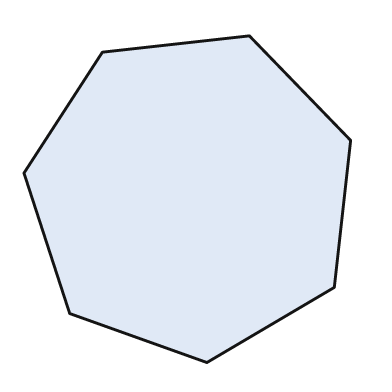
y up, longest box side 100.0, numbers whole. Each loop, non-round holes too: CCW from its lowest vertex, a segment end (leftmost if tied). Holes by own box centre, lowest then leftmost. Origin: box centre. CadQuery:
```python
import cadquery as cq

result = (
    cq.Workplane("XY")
    .moveTo(6.0, -50.0)
    .lineTo(45.0, -27.0)
    .lineTo(50.0, 18.0)
    .lineTo(19.0, 50.0)
    .lineTo(-26.0, 45.0)
    .lineTo(-50.0, 8.0)
    .lineTo(-36.0, -35.0)
    .close()
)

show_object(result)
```